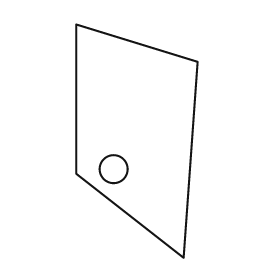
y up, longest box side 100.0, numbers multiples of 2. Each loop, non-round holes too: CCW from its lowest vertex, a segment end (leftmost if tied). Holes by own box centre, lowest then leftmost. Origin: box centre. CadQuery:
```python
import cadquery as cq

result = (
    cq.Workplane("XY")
    .moveTo(20.0, -50.0)
    .lineTo(26.0, 34.0)
    .lineTo(-26.0, 50.0)
    .lineTo(-26.0, -14.0)
    .close()
    .moveTo(-10.0, -12.0)
    .circle(6.0)
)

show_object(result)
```